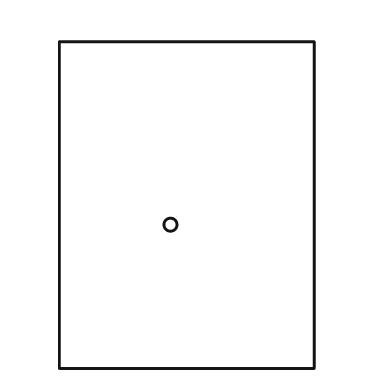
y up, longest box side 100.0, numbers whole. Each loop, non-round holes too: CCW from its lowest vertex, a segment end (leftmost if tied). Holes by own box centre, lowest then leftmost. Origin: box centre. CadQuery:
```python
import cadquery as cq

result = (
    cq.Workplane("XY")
    .moveTo(-39.0, -50.0)
    .lineTo(39.0, -50.0)
    .lineTo(39.0, 50.0)
    .lineTo(-39.0, 50.0)
    .close()
    .moveTo(-5.0, -6.0)
    .circle(2.0)
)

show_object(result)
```